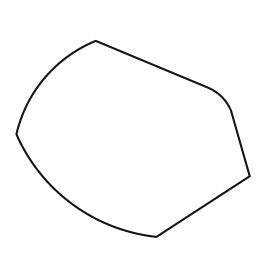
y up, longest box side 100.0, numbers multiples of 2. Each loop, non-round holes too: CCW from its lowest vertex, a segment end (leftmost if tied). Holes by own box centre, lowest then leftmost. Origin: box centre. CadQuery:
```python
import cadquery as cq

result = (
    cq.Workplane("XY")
    .moveTo(10.0, -42.0)
    .lineTo(50.0, -16.0)
    .lineTo(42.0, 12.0)
    .threePointArc((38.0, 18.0), (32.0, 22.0))
    .lineTo(-16.0, 42.0)
    .threePointArc((-38.0, 26.0), (-50.0, 2.0))
    .threePointArc((-26.0, -28.0), (10.0, -42.0))
    .close()
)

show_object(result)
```